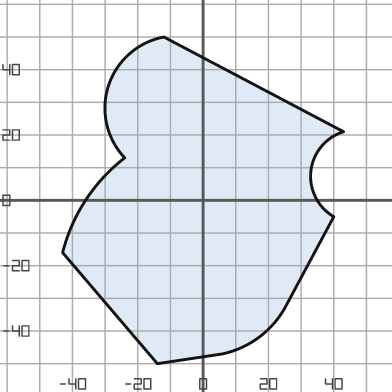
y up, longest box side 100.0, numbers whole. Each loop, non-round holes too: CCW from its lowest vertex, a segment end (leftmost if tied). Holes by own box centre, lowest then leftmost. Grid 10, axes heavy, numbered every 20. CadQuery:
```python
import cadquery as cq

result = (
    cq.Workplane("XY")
    .moveTo(-14.0, -50.0)
    .lineTo(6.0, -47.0)
    .threePointArc((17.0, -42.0), (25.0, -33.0))
    .lineTo(40.0, -5.0)
    .threePointArc((33.0, 9.0), (43.0, 21.0))
    .lineTo(-12.0, 50.0)
    .threePointArc((-29.0, 35.0), (-24.0, 13.0))
    .threePointArc((-36.0, 0.0), (-43.0, -16.0))
    .close()
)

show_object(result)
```